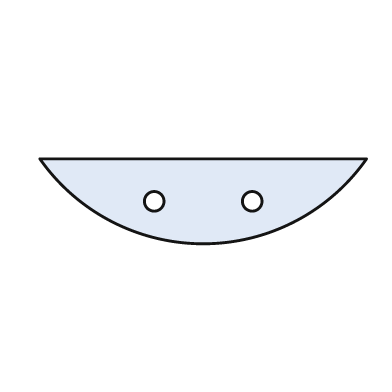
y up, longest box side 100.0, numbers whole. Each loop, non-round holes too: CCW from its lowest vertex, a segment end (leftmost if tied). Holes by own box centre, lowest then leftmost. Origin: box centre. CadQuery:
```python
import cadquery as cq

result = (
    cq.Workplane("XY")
    .moveTo(-50.0, 13.0)
    .threePointArc((0.0, -13.0), (50.0, 13.0))
    .close()
    .moveTo(-15.0, 0.0)
    .circle(3.0)
    .moveTo(15.0, 0.0)
    .circle(3.0)
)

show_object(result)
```